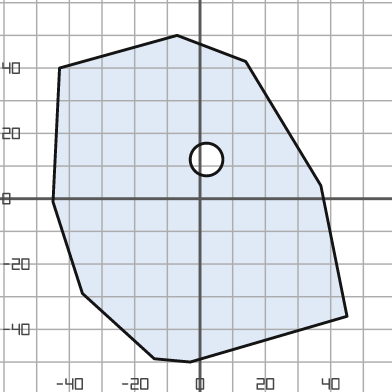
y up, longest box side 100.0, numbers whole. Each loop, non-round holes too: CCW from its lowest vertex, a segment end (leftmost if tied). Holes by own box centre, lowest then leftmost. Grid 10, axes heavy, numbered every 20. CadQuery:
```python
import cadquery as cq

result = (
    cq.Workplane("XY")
    .moveTo(-3.0, -50.0)
    .lineTo(45.0, -36.0)
    .lineTo(37.0, 4.0)
    .lineTo(14.0, 42.0)
    .lineTo(-7.0, 50.0)
    .lineTo(-43.0, 40.0)
    .lineTo(-45.0, -1.0)
    .lineTo(-36.0, -29.0)
    .lineTo(-14.0, -49.0)
    .close()
    .moveTo(2.0, 12.0)
    .circle(5.0)
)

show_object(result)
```